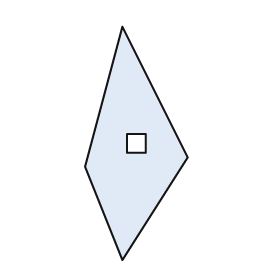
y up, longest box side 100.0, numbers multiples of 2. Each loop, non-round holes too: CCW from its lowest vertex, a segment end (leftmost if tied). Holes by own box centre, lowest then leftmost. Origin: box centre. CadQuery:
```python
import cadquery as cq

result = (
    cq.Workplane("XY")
    .moveTo(-6.0, -50.0)
    .lineTo(22.0, -6.0)
    .lineTo(-6.0, 50.0)
    .lineTo(-22.0, -10.0)
    .close()
    .moveTo(-4.0, -4.0)
    .lineTo(4.0, -4.0)
    .lineTo(4.0, 4.0)
    .lineTo(-4.0, 4.0)
    .close()
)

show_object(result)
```